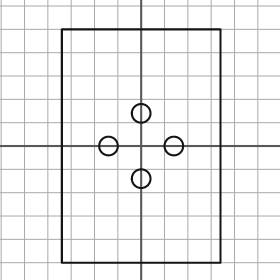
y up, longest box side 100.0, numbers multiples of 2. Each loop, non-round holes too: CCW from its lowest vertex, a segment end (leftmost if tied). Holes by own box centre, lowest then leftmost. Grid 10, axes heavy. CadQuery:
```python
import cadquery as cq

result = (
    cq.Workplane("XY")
    .moveTo(-34.0, -50.0)
    .lineTo(34.0, -50.0)
    .lineTo(34.0, 50.0)
    .lineTo(-34.0, 50.0)
    .close()
    .moveTo(0.0, -14.0)
    .circle(4.0)
    .moveTo(-14.0, 0.0)
    .circle(4.0)
    .moveTo(14.0, 0.0)
    .circle(4.0)
    .moveTo(0.0, 14.0)
    .circle(4.0)
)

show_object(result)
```